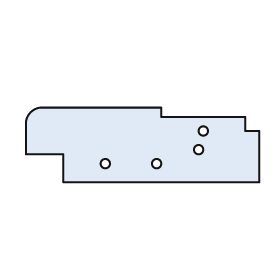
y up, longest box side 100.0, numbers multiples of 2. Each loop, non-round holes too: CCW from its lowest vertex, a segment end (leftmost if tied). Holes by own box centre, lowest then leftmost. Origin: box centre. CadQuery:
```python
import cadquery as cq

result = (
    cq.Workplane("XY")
    .moveTo(-34.0, -16.0)
    .lineTo(50.0, -16.0)
    .lineTo(50.0, 6.0)
    .lineTo(44.0, 6.0)
    .lineTo(44.0, 12.0)
    .lineTo(8.0, 12.0)
    .lineTo(8.0, 16.0)
    .lineTo(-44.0, 16.0)
    .threePointArc((-48.0, 14.0), (-50.0, 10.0))
    .lineTo(-50.0, -4.0)
    .lineTo(-34.0, -4.0)
    .close()
    .moveTo(-16.0, -8.0)
    .circle(2.0)
    .moveTo(6.0, -8.0)
    .circle(2.0)
    .moveTo(24.0, -2.0)
    .circle(2.0)
    .moveTo(26.0, 6.0)
    .circle(2.0)
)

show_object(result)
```